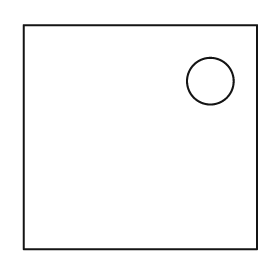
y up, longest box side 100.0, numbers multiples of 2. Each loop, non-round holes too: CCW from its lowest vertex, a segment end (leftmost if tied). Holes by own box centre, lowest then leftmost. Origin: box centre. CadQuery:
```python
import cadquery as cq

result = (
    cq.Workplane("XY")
    .moveTo(-50.0, -48.0)
    .lineTo(50.0, -48.0)
    .lineTo(50.0, 48.0)
    .lineTo(-50.0, 48.0)
    .close()
    .moveTo(30.0, 24.0)
    .circle(10.0)
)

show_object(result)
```